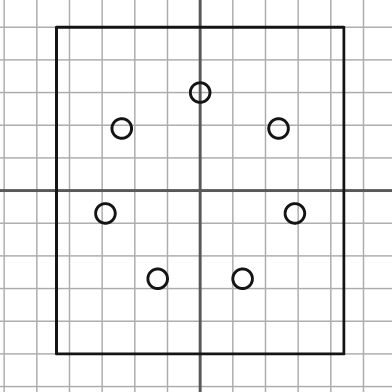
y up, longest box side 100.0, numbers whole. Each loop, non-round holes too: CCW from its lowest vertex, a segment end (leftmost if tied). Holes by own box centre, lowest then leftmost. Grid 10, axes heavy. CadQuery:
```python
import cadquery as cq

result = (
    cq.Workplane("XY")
    .moveTo(-44.0, -50.0)
    .lineTo(44.0, -50.0)
    .lineTo(44.0, 50.0)
    .lineTo(-44.0, 50.0)
    .close()
    .moveTo(-13.0, -27.0)
    .circle(3.0)
    .moveTo(13.0, -27.0)
    .circle(3.0)
    .moveTo(-29.0, -7.0)
    .circle(3.0)
    .moveTo(29.0, -7.0)
    .circle(3.0)
    .moveTo(-24.0, 19.0)
    .circle(3.0)
    .moveTo(24.0, 19.0)
    .circle(3.0)
    .moveTo(0.0, 30.0)
    .circle(3.0)
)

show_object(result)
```